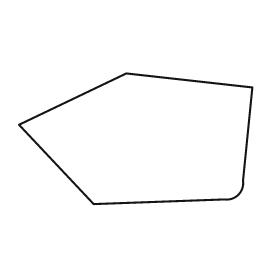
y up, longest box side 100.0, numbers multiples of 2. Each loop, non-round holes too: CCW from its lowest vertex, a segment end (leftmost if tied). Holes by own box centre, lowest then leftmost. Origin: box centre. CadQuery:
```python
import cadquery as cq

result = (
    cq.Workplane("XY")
    .moveTo(-18.0, -28.0)
    .lineTo(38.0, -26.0)
    .threePointArc((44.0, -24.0), (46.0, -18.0))
    .lineTo(50.0, 22.0)
    .lineTo(-4.0, 28.0)
    .lineTo(-50.0, 6.0)
    .close()
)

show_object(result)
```